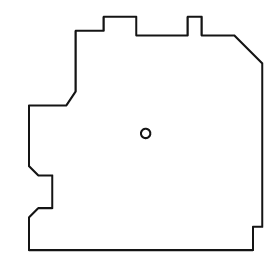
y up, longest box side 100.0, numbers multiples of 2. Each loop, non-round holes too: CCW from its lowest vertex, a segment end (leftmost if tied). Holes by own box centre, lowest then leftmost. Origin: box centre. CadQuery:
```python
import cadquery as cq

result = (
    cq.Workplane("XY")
    .moveTo(-50.0, -50.0)
    .lineTo(46.0, -50.0)
    .lineTo(46.0, -40.0)
    .lineTo(50.0, -40.0)
    .lineTo(50.0, 30.0)
    .lineTo(38.0, 42.0)
    .lineTo(24.0, 42.0)
    .lineTo(24.0, 50.0)
    .lineTo(18.0, 50.0)
    .lineTo(18.0, 42.0)
    .lineTo(-4.0, 42.0)
    .lineTo(-4.0, 50.0)
    .lineTo(-18.0, 50.0)
    .lineTo(-18.0, 44.0)
    .lineTo(-30.0, 44.0)
    .lineTo(-30.0, 18.0)
    .lineTo(-34.0, 12.0)
    .lineTo(-50.0, 12.0)
    .lineTo(-50.0, -14.0)
    .lineTo(-46.0, -18.0)
    .lineTo(-40.0, -18.0)
    .lineTo(-40.0, -32.0)
    .lineTo(-46.0, -32.0)
    .lineTo(-50.0, -36.0)
    .close()
    .moveTo(0.0, 0.0)
    .circle(2.0)
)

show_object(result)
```